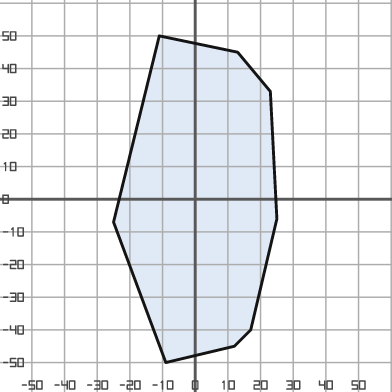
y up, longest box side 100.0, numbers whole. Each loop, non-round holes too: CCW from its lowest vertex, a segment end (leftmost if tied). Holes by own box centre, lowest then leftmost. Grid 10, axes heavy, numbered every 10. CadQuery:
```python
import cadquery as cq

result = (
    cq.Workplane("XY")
    .moveTo(-9.0, -50.0)
    .lineTo(12.0, -45.0)
    .lineTo(17.0, -40.0)
    .lineTo(25.0, -6.0)
    .lineTo(23.0, 33.0)
    .lineTo(13.0, 45.0)
    .lineTo(-11.0, 50.0)
    .lineTo(-25.0, -7.0)
    .close()
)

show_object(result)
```